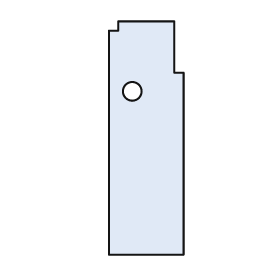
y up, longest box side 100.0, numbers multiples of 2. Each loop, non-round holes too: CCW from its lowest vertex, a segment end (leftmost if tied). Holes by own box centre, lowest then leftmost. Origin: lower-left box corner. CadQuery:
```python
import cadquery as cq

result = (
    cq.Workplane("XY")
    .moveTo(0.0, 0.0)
    .lineTo(32.0, 0.0)
    .lineTo(32.0, 78.0)
    .lineTo(28.0, 78.0)
    .lineTo(28.0, 100.0)
    .lineTo(4.0, 100.0)
    .lineTo(4.0, 96.0)
    .lineTo(0.0, 96.0)
    .close()
    .moveTo(10.0, 70.0)
    .circle(4.0)
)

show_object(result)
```